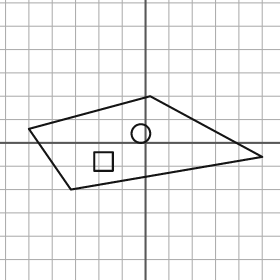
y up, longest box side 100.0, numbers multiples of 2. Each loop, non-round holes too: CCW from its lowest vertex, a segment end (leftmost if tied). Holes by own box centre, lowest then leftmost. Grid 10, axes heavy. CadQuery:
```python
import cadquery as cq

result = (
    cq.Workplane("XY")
    .moveTo(-32.0, -20.0)
    .lineTo(50.0, -6.0)
    .lineTo(2.0, 20.0)
    .lineTo(-50.0, 6.0)
    .close()
    .moveTo(-22.0, -12.0)
    .lineTo(-14.0, -12.0)
    .lineTo(-14.0, -4.0)
    .lineTo(-22.0, -4.0)
    .close()
    .moveTo(-2.0, 4.0)
    .circle(4.0)
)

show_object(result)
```